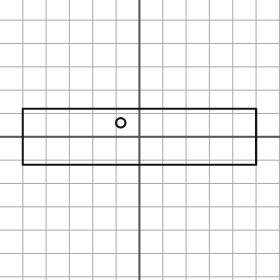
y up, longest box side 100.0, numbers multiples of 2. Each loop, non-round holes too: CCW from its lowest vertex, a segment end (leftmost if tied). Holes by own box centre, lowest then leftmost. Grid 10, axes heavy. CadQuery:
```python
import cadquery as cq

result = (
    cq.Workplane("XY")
    .moveTo(-50.0, -12.0)
    .lineTo(50.0, -12.0)
    .lineTo(50.0, 12.0)
    .lineTo(-50.0, 12.0)
    .close()
    .moveTo(-8.0, 6.0)
    .circle(2.0)
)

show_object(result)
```